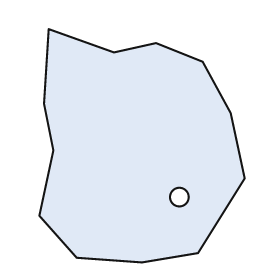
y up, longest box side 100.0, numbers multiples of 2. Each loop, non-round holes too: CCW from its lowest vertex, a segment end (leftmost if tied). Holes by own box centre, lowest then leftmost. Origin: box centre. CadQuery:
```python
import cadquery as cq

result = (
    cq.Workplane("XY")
    .moveTo(0.0, -50.0)
    .lineTo(24.0, -46.0)
    .lineTo(44.0, -14.0)
    .lineTo(38.0, 14.0)
    .lineTo(26.0, 36.0)
    .lineTo(6.0, 44.0)
    .lineTo(-12.0, 40.0)
    .lineTo(-40.0, 50.0)
    .lineTo(-42.0, 18.0)
    .lineTo(-38.0, -2.0)
    .lineTo(-44.0, -30.0)
    .lineTo(-28.0, -48.0)
    .close()
    .moveTo(16.0, -22.0)
    .circle(4.0)
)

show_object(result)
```